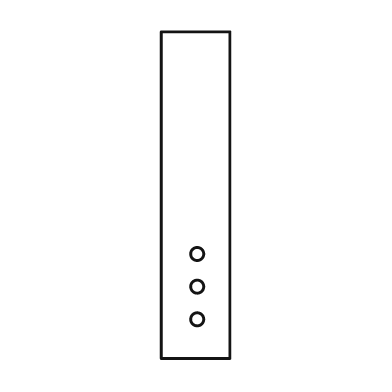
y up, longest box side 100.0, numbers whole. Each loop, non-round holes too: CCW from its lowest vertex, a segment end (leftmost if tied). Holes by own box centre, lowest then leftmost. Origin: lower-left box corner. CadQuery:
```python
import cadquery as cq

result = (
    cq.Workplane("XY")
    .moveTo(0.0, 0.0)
    .lineTo(21.0, 0.0)
    .lineTo(21.0, 100.0)
    .lineTo(0.0, 100.0)
    .close()
    .moveTo(11.0, 12.0)
    .circle(2.0)
    .moveTo(11.0, 22.0)
    .circle(2.0)
    .moveTo(11.0, 32.0)
    .circle(2.0)
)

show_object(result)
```